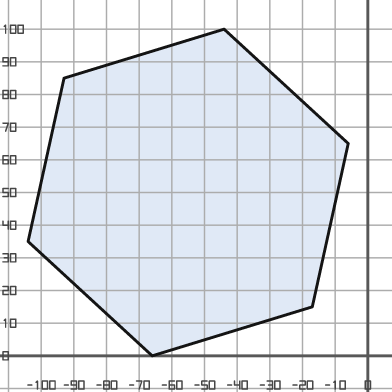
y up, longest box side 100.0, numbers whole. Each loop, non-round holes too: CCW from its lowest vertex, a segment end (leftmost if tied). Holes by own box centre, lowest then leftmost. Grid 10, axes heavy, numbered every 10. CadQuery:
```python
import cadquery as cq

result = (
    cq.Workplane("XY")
    .moveTo(-66.0, 0.0)
    .lineTo(-17.0, 15.0)
    .lineTo(-6.0, 65.0)
    .lineTo(-44.0, 100.0)
    .lineTo(-93.0, 85.0)
    .lineTo(-104.0, 35.0)
    .close()
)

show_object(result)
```